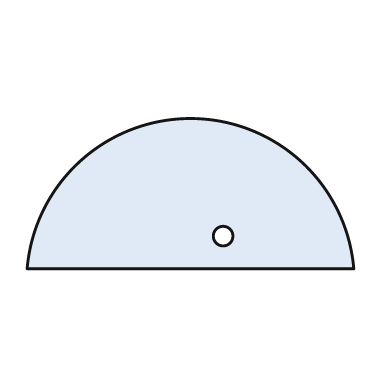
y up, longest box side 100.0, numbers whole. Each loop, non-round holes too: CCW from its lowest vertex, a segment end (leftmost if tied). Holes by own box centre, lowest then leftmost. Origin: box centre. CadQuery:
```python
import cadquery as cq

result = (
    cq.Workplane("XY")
    .moveTo(-50.0, -23.0)
    .lineTo(50.0, -23.0)
    .threePointArc((0.0, 23.0), (-50.0, -23.0))
    .close()
    .moveTo(10.0, -13.0)
    .circle(3.0)
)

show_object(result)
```